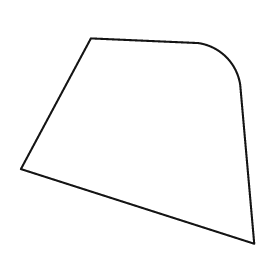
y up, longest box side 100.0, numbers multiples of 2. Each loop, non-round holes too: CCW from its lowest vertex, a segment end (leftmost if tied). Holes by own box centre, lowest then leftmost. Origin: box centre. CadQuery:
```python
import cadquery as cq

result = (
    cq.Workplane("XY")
    .moveTo(50.0, -44.0)
    .lineTo(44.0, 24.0)
    .threePointArc((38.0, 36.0), (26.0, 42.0))
    .lineTo(-20.0, 44.0)
    .lineTo(-50.0, -12.0)
    .close()
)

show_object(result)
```